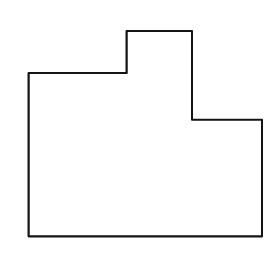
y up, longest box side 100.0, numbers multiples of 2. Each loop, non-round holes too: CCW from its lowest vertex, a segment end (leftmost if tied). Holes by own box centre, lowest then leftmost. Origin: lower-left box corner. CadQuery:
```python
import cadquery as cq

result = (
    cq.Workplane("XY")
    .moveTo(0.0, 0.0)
    .lineTo(100.0, 0.0)
    .lineTo(100.0, 50.0)
    .lineTo(70.0, 50.0)
    .lineTo(70.0, 88.0)
    .lineTo(42.0, 88.0)
    .lineTo(42.0, 70.0)
    .lineTo(0.0, 70.0)
    .close()
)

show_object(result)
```